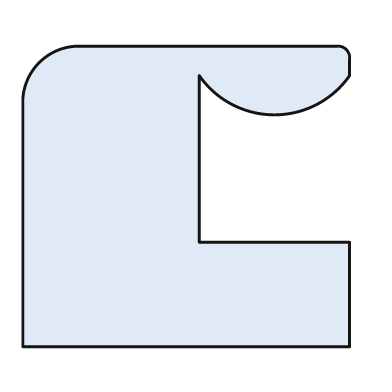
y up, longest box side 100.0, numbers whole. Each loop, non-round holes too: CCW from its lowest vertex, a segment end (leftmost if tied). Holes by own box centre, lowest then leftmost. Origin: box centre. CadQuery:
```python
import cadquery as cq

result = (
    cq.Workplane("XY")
    .moveTo(-50.0, -46.0)
    .lineTo(50.0, -46.0)
    .lineTo(50.0, -14.0)
    .lineTo(4.0, -14.0)
    .lineTo(4.0, 37.0)
    .threePointArc((27.0, 25.0), (50.0, 37.0))
    .lineTo(50.0, 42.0)
    .threePointArc((49.0, 45.0), (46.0, 46.0))
    .lineTo(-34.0, 46.0)
    .threePointArc((-45.0, 41.0), (-50.0, 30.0))
    .close()
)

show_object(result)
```